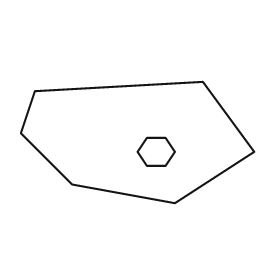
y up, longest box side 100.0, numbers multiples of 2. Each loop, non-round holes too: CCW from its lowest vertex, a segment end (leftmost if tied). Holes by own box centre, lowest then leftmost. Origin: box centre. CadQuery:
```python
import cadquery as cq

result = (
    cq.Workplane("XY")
    .moveTo(16.0, -26.0)
    .lineTo(50.0, -4.0)
    .lineTo(28.0, 26.0)
    .lineTo(-44.0, 22.0)
    .lineTo(-50.0, 4.0)
    .lineTo(-28.0, -18.0)
    .close()
    .moveTo(4.0, -10.0)
    .lineTo(12.0, -10.0)
    .lineTo(16.0, -4.0)
    .lineTo(12.0, 2.0)
    .lineTo(4.0, 2.0)
    .lineTo(0.0, -4.0)
    .close()
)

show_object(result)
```